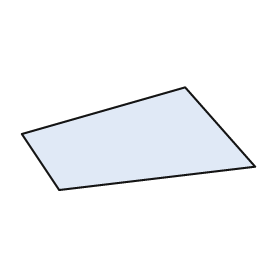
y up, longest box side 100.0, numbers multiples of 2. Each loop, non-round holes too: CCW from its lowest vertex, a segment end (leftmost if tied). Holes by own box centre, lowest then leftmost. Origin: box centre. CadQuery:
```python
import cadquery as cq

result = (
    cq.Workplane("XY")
    .moveTo(-34.0, -22.0)
    .lineTo(50.0, -12.0)
    .lineTo(20.0, 22.0)
    .lineTo(-50.0, 2.0)
    .close()
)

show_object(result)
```